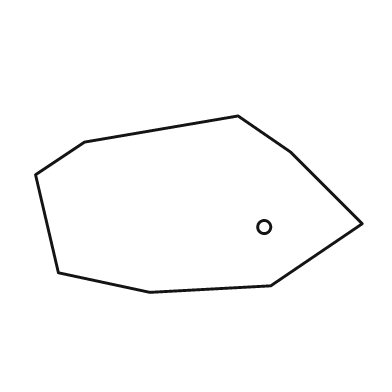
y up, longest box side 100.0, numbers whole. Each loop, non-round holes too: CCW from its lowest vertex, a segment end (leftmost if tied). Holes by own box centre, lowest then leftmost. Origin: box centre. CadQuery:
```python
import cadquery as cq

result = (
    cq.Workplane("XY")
    .moveTo(-15.0, -27.0)
    .lineTo(22.0, -25.0)
    .lineTo(50.0, -6.0)
    .lineTo(28.0, 16.0)
    .lineTo(12.0, 27.0)
    .lineTo(-35.0, 19.0)
    .lineTo(-50.0, 9.0)
    .lineTo(-43.0, -21.0)
    .close()
    .moveTo(20.0, -7.0)
    .circle(2.0)
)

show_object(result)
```